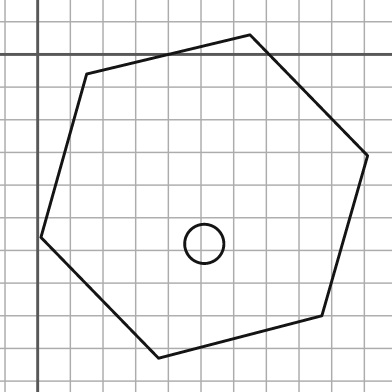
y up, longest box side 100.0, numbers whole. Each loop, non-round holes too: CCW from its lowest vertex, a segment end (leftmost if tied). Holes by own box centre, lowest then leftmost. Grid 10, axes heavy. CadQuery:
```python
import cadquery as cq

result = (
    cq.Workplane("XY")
    .moveTo(37.0, -93.0)
    .lineTo(87.0, -80.0)
    .lineTo(101.0, -31.0)
    .lineTo(65.0, 6.0)
    .lineTo(15.0, -6.0)
    .lineTo(1.0, -56.0)
    .close()
    .moveTo(51.0, -58.0)
    .circle(6.0)
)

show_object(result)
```